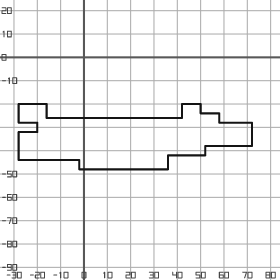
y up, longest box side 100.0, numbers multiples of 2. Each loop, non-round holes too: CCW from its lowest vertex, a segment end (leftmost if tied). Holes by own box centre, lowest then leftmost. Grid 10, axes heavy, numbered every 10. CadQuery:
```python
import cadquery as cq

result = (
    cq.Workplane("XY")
    .moveTo(-2.0, -48.0)
    .lineTo(36.0, -48.0)
    .lineTo(36.0, -42.0)
    .lineTo(52.0, -42.0)
    .lineTo(52.0, -38.0)
    .lineTo(72.0, -38.0)
    .lineTo(72.0, -28.0)
    .lineTo(58.0, -28.0)
    .lineTo(58.0, -24.0)
    .lineTo(50.0, -24.0)
    .lineTo(50.0, -20.0)
    .lineTo(42.0, -20.0)
    .lineTo(42.0, -26.0)
    .lineTo(-16.0, -26.0)
    .lineTo(-16.0, -20.0)
    .lineTo(-28.0, -20.0)
    .lineTo(-28.0, -28.0)
    .lineTo(-20.0, -28.0)
    .lineTo(-20.0, -32.0)
    .lineTo(-28.0, -32.0)
    .lineTo(-28.0, -44.0)
    .lineTo(-2.0, -44.0)
    .close()
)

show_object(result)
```